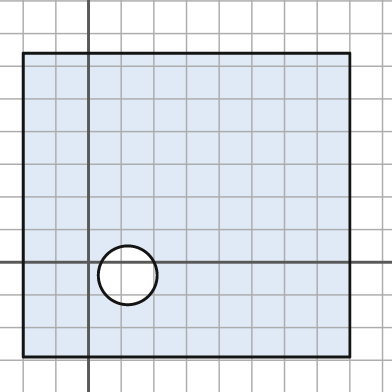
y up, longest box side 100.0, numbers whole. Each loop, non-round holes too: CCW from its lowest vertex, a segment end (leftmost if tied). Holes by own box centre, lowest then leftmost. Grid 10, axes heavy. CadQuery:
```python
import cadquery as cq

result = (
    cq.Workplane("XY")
    .moveTo(-20.0, -29.0)
    .lineTo(80.0, -29.0)
    .lineTo(80.0, 64.0)
    .lineTo(-20.0, 64.0)
    .close()
    .moveTo(12.0, -4.0)
    .circle(9.0)
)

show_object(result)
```